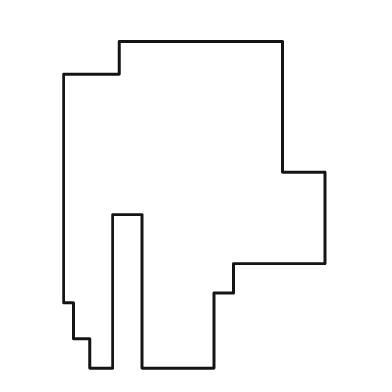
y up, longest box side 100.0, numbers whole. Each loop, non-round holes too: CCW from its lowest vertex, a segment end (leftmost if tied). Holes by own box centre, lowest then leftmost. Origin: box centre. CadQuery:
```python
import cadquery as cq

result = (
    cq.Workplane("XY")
    .moveTo(-32.0, -50.0)
    .lineTo(-25.0, -50.0)
    .lineTo(-25.0, -3.0)
    .lineTo(-16.0, -3.0)
    .lineTo(-16.0, -50.0)
    .lineTo(6.0, -50.0)
    .lineTo(6.0, -27.0)
    .lineTo(12.0, -27.0)
    .lineTo(12.0, -18.0)
    .lineTo(40.0, -18.0)
    .lineTo(40.0, 10.0)
    .lineTo(27.0, 10.0)
    .lineTo(27.0, 50.0)
    .lineTo(-23.0, 50.0)
    .lineTo(-23.0, 40.0)
    .lineTo(-40.0, 40.0)
    .lineTo(-40.0, -30.0)
    .lineTo(-37.0, -30.0)
    .lineTo(-37.0, -41.0)
    .lineTo(-32.0, -41.0)
    .close()
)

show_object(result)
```